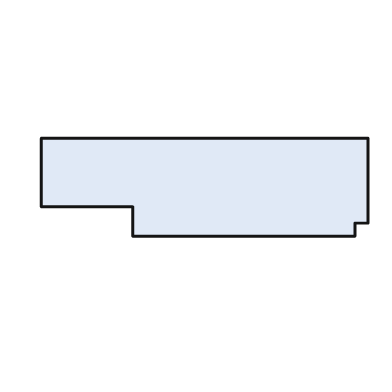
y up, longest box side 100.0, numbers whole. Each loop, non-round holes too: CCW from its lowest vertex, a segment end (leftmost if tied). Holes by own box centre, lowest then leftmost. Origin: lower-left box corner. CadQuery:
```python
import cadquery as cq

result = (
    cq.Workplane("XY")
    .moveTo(28.0, 0.0)
    .lineTo(96.0, 0.0)
    .lineTo(96.0, 4.0)
    .lineTo(100.0, 4.0)
    .lineTo(100.0, 30.0)
    .lineTo(0.0, 30.0)
    .lineTo(0.0, 9.0)
    .lineTo(28.0, 9.0)
    .close()
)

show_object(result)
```